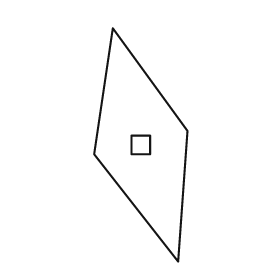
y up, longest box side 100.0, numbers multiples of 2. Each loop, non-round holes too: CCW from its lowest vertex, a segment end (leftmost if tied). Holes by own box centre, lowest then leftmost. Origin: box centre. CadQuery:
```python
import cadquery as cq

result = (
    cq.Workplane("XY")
    .moveTo(16.0, -50.0)
    .lineTo(20.0, 6.0)
    .lineTo(-12.0, 50.0)
    .lineTo(-20.0, -4.0)
    .close()
    .moveTo(-4.0, -4.0)
    .lineTo(4.0, -4.0)
    .lineTo(4.0, 4.0)
    .lineTo(-4.0, 4.0)
    .close()
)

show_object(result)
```